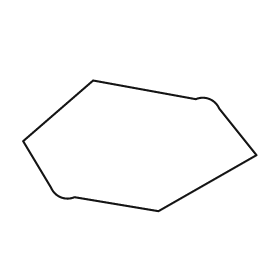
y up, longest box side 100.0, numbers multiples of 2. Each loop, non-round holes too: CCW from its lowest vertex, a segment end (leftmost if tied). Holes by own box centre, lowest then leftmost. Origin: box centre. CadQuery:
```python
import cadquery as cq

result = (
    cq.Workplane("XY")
    .moveTo(8.0, -28.0)
    .lineTo(50.0, -4.0)
    .lineTo(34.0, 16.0)
    .threePointArc((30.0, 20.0), (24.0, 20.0))
    .lineTo(-20.0, 28.0)
    .lineTo(-50.0, 2.0)
    .lineTo(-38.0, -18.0)
    .threePointArc((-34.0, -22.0), (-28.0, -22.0))
    .close()
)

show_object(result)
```